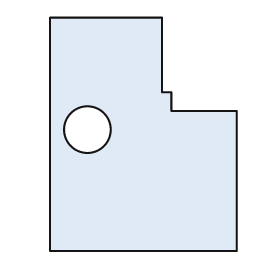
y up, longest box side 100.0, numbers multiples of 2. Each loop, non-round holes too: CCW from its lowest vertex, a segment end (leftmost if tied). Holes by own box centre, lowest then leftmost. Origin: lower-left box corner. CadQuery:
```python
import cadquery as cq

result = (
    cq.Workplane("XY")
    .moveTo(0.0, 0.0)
    .lineTo(80.0, 0.0)
    .lineTo(80.0, 60.0)
    .lineTo(52.0, 60.0)
    .lineTo(52.0, 68.0)
    .lineTo(48.0, 68.0)
    .lineTo(48.0, 100.0)
    .lineTo(0.0, 100.0)
    .close()
    .moveTo(16.0, 52.0)
    .circle(10.0)
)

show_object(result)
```